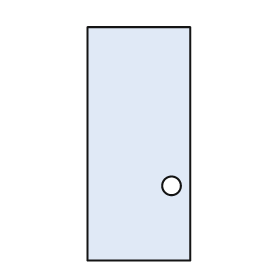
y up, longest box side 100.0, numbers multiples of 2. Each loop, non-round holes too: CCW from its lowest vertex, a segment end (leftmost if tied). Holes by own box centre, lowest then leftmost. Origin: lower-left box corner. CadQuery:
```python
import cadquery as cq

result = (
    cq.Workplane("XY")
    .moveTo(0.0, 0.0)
    .lineTo(44.0, 0.0)
    .lineTo(44.0, 100.0)
    .lineTo(0.0, 100.0)
    .close()
    .moveTo(36.0, 32.0)
    .circle(4.0)
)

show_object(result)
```